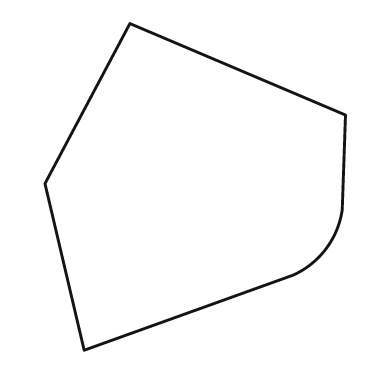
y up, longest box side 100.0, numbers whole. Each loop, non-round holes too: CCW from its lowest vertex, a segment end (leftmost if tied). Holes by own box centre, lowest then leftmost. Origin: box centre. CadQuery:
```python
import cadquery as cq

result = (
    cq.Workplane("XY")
    .moveTo(-34.0, -50.0)
    .lineTo(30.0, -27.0)
    .threePointArc((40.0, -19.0), (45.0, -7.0))
    .lineTo(46.0, 22.0)
    .lineTo(-20.0, 50.0)
    .lineTo(-46.0, 1.0)
    .close()
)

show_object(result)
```